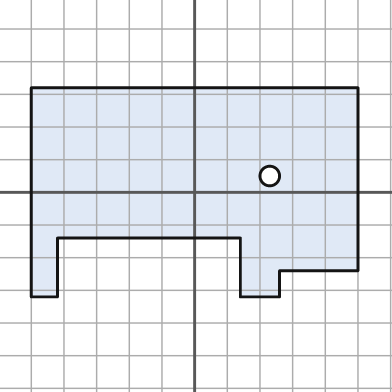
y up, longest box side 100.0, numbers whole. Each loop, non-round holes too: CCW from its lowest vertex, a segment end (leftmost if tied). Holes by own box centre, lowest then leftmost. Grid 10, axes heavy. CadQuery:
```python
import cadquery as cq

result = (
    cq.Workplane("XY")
    .moveTo(-50.0, -32.0)
    .lineTo(-42.0, -32.0)
    .lineTo(-42.0, -14.0)
    .lineTo(14.0, -14.0)
    .lineTo(14.0, -32.0)
    .lineTo(26.0, -32.0)
    .lineTo(26.0, -24.0)
    .lineTo(50.0, -24.0)
    .lineTo(50.0, 32.0)
    .lineTo(-50.0, 32.0)
    .close()
    .moveTo(23.0, 5.0)
    .circle(3.0)
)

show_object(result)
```